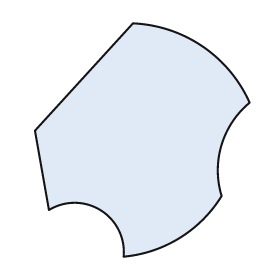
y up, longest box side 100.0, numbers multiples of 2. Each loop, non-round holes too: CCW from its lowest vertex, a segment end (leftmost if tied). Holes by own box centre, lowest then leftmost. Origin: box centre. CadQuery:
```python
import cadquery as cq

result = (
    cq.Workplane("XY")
    .moveTo(-8.0, -50.0)
    .threePointArc((16.0, -42.0), (34.0, -24.0))
    .threePointArc((34.0, -2.0), (46.0, 16.0))
    .threePointArc((26.0, 40.0), (-4.0, 50.0))
    .lineTo(-46.0, 4.0)
    .lineTo(-40.0, -30.0)
    .threePointArc((-18.0, -30.0), (-8.0, -50.0))
    .close()
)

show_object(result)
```